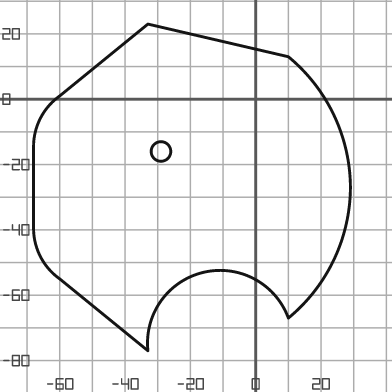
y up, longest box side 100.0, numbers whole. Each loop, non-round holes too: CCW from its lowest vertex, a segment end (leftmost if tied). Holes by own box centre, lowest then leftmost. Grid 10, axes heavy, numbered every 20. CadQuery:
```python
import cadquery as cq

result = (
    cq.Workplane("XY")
    .moveTo(-33.0, -77.0)
    .threePointArc((-16.0, -53.0), (10.0, -67.0))
    .threePointArc((24.0, -49.0), (29.0, -27.0))
    .threePointArc((24.0, -5.0), (10.0, 13.0))
    .lineTo(-33.0, 23.0)
    .lineTo(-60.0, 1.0)
    .threePointArc((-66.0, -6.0), (-68.0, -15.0))
    .lineTo(-68.0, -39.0)
    .threePointArc((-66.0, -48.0), (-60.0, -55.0))
    .close()
    .moveTo(-29.0, -16.0)
    .circle(3.0)
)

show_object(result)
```